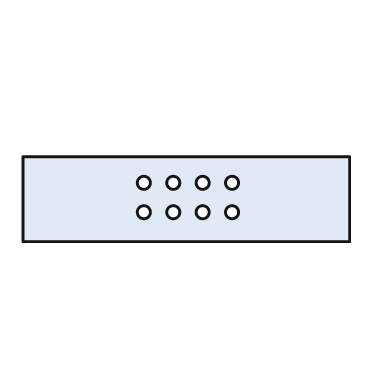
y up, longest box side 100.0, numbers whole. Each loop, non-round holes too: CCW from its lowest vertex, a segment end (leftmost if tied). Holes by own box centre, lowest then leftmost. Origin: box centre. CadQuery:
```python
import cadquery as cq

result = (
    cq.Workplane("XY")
    .moveTo(-50.0, -13.0)
    .lineTo(50.0, -13.0)
    .lineTo(50.0, 13.0)
    .lineTo(-50.0, 13.0)
    .close()
    .moveTo(-13.0, -4.0)
    .circle(2.0)
    .moveTo(-4.0, -4.0)
    .circle(2.0)
    .moveTo(5.0, -4.0)
    .circle(2.0)
    .moveTo(14.0, -4.0)
    .circle(2.0)
    .moveTo(-13.0, 5.0)
    .circle(2.0)
    .moveTo(-4.0, 5.0)
    .circle(2.0)
    .moveTo(5.0, 5.0)
    .circle(2.0)
    .moveTo(14.0, 5.0)
    .circle(2.0)
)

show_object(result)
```